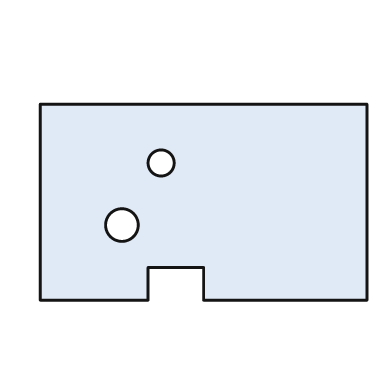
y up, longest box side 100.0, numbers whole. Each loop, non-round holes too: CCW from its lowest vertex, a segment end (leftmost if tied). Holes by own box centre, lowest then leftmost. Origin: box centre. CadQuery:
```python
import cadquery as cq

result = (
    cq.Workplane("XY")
    .moveTo(-50.0, -30.0)
    .lineTo(-17.0, -30.0)
    .lineTo(-17.0, -20.0)
    .lineTo(0.0, -20.0)
    .lineTo(0.0, -30.0)
    .lineTo(50.0, -30.0)
    .lineTo(50.0, 30.0)
    .lineTo(-50.0, 30.0)
    .close()
    .moveTo(-25.0, -7.0)
    .circle(5.0)
    .moveTo(-13.0, 12.0)
    .circle(4.0)
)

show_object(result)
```